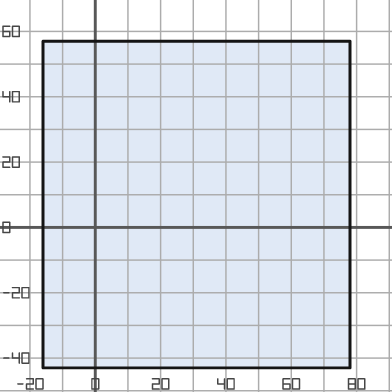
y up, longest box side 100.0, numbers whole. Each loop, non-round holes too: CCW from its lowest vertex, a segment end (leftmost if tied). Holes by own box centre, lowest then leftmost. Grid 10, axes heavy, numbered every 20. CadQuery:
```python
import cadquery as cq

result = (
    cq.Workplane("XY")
    .moveTo(-16.0, -43.0)
    .lineTo(78.0, -43.0)
    .lineTo(78.0, 57.0)
    .lineTo(-16.0, 57.0)
    .close()
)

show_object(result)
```